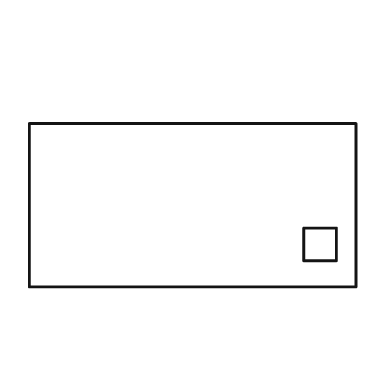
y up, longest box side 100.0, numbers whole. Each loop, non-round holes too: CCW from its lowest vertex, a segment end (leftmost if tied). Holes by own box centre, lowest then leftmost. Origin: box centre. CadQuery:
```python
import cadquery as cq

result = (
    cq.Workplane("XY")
    .moveTo(-50.0, -25.0)
    .lineTo(50.0, -25.0)
    .lineTo(50.0, 25.0)
    .lineTo(-50.0, 25.0)
    .close()
    .moveTo(34.0, -17.0)
    .lineTo(44.0, -17.0)
    .lineTo(44.0, -7.0)
    .lineTo(34.0, -7.0)
    .close()
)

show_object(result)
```